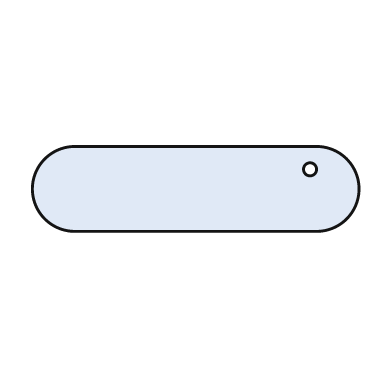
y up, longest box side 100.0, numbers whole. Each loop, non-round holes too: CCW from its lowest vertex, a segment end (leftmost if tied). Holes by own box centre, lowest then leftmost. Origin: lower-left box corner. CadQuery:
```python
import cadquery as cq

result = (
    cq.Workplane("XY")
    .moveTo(13.0, 0.0)
    .lineTo(87.0, 0.0)
    .threePointArc((100.0, 13.0), (87.0, 26.0))
    .lineTo(13.0, 26.0)
    .threePointArc((0.0, 13.0), (13.0, 0.0))
    .close()
    .moveTo(85.0, 19.0)
    .circle(2.0)
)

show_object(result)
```